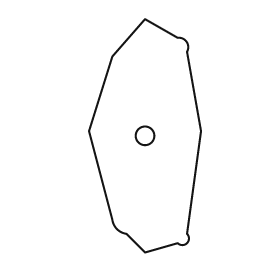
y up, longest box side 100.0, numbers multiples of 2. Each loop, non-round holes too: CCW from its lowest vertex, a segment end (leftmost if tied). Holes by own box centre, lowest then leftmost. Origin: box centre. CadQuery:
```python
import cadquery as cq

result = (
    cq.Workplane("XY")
    .moveTo(0.0, -50.0)
    .lineTo(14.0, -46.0)
    .threePointArc((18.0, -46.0), (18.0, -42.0))
    .lineTo(24.0, 2.0)
    .lineTo(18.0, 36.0)
    .threePointArc((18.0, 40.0), (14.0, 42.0))
    .lineTo(0.0, 50.0)
    .lineTo(-14.0, 34.0)
    .lineTo(-24.0, 2.0)
    .lineTo(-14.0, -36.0)
    .threePointArc((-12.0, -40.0), (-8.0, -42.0))
    .close()
    .moveTo(0.0, 0.0)
    .circle(4.0)
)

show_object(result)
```